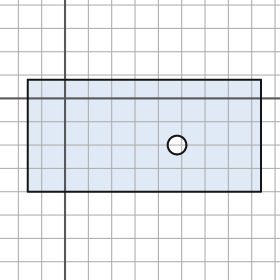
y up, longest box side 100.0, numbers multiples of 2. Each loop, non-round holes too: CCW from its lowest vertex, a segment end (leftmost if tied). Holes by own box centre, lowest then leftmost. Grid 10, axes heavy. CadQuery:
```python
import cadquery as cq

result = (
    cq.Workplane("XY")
    .moveTo(-16.0, -40.0)
    .lineTo(84.0, -40.0)
    .lineTo(84.0, 8.0)
    .lineTo(-16.0, 8.0)
    .close()
    .moveTo(48.0, -20.0)
    .circle(4.0)
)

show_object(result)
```